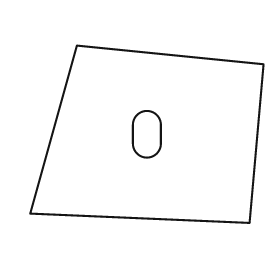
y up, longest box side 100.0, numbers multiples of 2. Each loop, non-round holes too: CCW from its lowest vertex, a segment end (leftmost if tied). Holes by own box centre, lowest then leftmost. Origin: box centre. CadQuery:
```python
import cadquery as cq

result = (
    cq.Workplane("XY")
    .moveTo(44.0, -38.0)
    .lineTo(50.0, 30.0)
    .lineTo(-30.0, 38.0)
    .lineTo(-50.0, -34.0)
    .close()
    .moveTo(-6.0, -4.0)
    .threePointArc((0.0, -10.0), (6.0, -4.0))
    .lineTo(6.0, 4.0)
    .threePointArc((0.0, 10.0), (-6.0, 4.0))
    .close()
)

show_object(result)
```